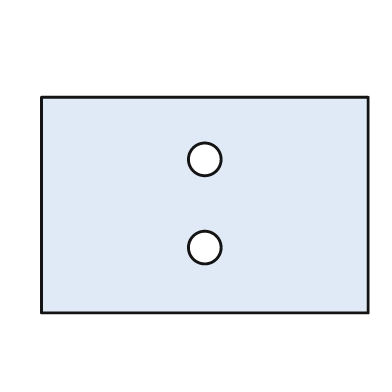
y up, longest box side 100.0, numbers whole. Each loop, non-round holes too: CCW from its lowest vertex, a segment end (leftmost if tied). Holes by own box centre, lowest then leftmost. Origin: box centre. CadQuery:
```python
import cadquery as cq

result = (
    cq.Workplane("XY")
    .moveTo(-50.0, -33.0)
    .lineTo(50.0, -33.0)
    .lineTo(50.0, 33.0)
    .lineTo(-50.0, 33.0)
    .close()
    .moveTo(0.0, -13.0)
    .circle(5.0)
    .moveTo(0.0, 14.0)
    .circle(5.0)
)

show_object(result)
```